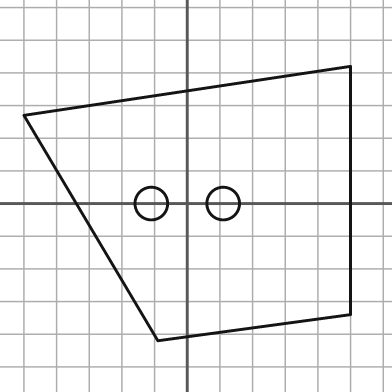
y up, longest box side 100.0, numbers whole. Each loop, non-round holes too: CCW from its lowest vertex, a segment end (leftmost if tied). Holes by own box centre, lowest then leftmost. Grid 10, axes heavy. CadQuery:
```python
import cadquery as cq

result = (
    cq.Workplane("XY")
    .moveTo(-9.0, -42.0)
    .lineTo(50.0, -34.0)
    .lineTo(50.0, 42.0)
    .lineTo(-50.0, 27.0)
    .close()
    .moveTo(-11.0, 0.0)
    .circle(5.0)
    .moveTo(11.0, 0.0)
    .circle(5.0)
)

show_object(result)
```